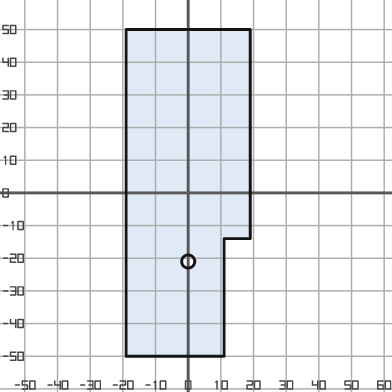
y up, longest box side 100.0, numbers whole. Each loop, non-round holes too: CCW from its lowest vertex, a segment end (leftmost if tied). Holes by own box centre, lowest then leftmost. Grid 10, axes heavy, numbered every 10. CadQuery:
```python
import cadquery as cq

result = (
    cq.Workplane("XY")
    .moveTo(-19.0, -50.0)
    .lineTo(11.0, -50.0)
    .lineTo(11.0, -14.0)
    .lineTo(19.0, -14.0)
    .lineTo(19.0, 50.0)
    .lineTo(-19.0, 50.0)
    .close()
    .moveTo(0.0, -21.0)
    .circle(2.0)
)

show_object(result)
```